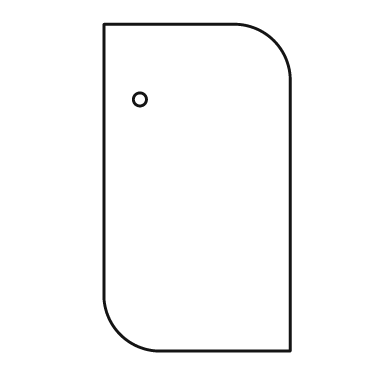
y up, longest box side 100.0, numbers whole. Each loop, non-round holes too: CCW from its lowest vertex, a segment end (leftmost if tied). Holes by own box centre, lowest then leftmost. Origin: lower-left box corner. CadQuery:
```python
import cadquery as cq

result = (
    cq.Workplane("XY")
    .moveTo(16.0, 0.0)
    .lineTo(57.0, 0.0)
    .lineTo(57.0, 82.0)
    .threePointArc((52.0, 95.0), (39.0, 100.0))
    .lineTo(0.0, 100.0)
    .lineTo(0.0, 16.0)
    .threePointArc((5.0, 5.0), (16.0, 0.0))
    .close()
    .moveTo(11.0, 77.0)
    .circle(2.0)
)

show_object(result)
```